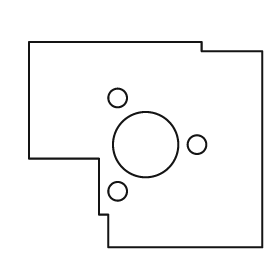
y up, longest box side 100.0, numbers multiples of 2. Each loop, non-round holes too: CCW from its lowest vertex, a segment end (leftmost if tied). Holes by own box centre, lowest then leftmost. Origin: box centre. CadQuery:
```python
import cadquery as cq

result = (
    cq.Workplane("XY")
    .moveTo(-16.0, -44.0)
    .lineTo(50.0, -44.0)
    .lineTo(50.0, 40.0)
    .lineTo(24.0, 40.0)
    .lineTo(24.0, 44.0)
    .lineTo(-50.0, 44.0)
    .lineTo(-50.0, -6.0)
    .lineTo(-20.0, -6.0)
    .lineTo(-20.0, -30.0)
    .lineTo(-16.0, -30.0)
    .close()
    .moveTo(-12.0, -20.0)
    .circle(4.0)
    .moveTo(0.0, 0.0)
    .circle(14.0)
    .moveTo(22.0, 0.0)
    .circle(4.0)
    .moveTo(-12.0, 20.0)
    .circle(4.0)
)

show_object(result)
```